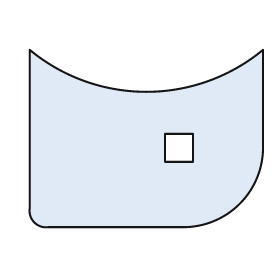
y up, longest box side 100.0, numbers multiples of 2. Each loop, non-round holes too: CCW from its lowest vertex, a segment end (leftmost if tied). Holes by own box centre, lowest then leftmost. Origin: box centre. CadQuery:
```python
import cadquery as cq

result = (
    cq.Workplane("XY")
    .moveTo(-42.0, -38.0)
    .lineTo(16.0, -38.0)
    .threePointArc((40.0, -28.0), (50.0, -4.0))
    .lineTo(50.0, 38.0)
    .threePointArc((0.0, 20.0), (-50.0, 38.0))
    .lineTo(-50.0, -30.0)
    .threePointArc((-48.0, -36.0), (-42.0, -38.0))
    .close()
    .moveTo(8.0, -10.0)
    .lineTo(20.0, -10.0)
    .lineTo(20.0, 2.0)
    .lineTo(8.0, 2.0)
    .close()
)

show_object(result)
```